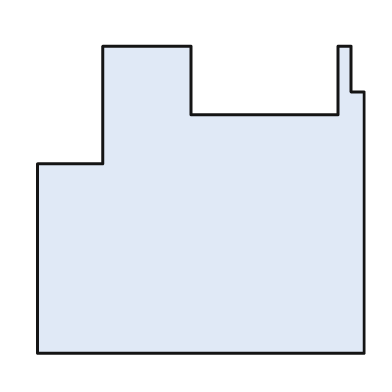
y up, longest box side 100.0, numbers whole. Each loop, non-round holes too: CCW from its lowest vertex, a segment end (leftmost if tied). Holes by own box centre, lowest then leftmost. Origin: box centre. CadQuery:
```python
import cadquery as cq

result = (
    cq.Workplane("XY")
    .moveTo(-50.0, -47.0)
    .lineTo(50.0, -47.0)
    .lineTo(50.0, 33.0)
    .lineTo(46.0, 33.0)
    .lineTo(46.0, 47.0)
    .lineTo(42.0, 47.0)
    .lineTo(42.0, 26.0)
    .lineTo(-3.0, 26.0)
    .lineTo(-3.0, 47.0)
    .lineTo(-30.0, 47.0)
    .lineTo(-30.0, 11.0)
    .lineTo(-50.0, 11.0)
    .close()
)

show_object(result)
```